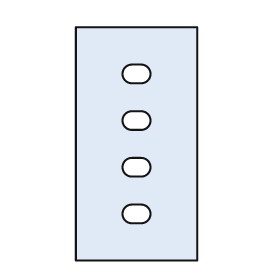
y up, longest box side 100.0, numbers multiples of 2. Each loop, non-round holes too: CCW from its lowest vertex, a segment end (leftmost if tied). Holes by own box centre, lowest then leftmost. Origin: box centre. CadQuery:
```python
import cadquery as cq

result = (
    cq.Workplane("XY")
    .moveTo(-26.0, -50.0)
    .lineTo(26.0, -50.0)
    .lineTo(26.0, 50.0)
    .lineTo(-26.0, 50.0)
    .close()
    .moveTo(-2.0, -34.0)
    .lineTo(2.0, -34.0)
    .threePointArc((6.0, -30.0), (2.0, -26.0))
    .lineTo(-2.0, -26.0)
    .threePointArc((-6.0, -30.0), (-2.0, -34.0))
    .close()
    .moveTo(-2.0, -14.0)
    .lineTo(2.0, -14.0)
    .threePointArc((6.0, -10.0), (2.0, -6.0))
    .lineTo(-2.0, -6.0)
    .threePointArc((-6.0, -10.0), (-2.0, -14.0))
    .close()
    .moveTo(-2.0, 6.0)
    .lineTo(2.0, 6.0)
    .threePointArc((6.0, 10.0), (2.0, 14.0))
    .lineTo(-2.0, 14.0)
    .threePointArc((-6.0, 10.0), (-2.0, 6.0))
    .close()
    .moveTo(-2.0, 26.0)
    .lineTo(2.0, 26.0)
    .threePointArc((6.0, 30.0), (2.0, 34.0))
    .lineTo(-2.0, 34.0)
    .threePointArc((-6.0, 30.0), (-2.0, 26.0))
    .close()
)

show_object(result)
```